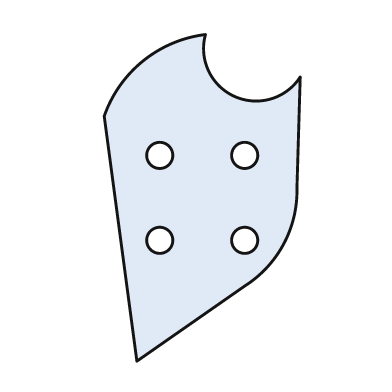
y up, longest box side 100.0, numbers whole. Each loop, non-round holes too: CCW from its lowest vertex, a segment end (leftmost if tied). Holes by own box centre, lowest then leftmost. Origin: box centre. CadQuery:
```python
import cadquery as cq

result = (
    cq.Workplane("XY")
    .moveTo(-20.0, -50.0)
    .lineTo(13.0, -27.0)
    .threePointArc((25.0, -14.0), (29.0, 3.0))
    .lineTo(30.0, 37.0)
    .threePointArc((10.0, 31.0), (1.0, 50.0))
    .threePointArc((-18.0, 42.0), (-30.0, 25.0))
    .close()
    .moveTo(-13.0, -13.0)
    .circle(4.0)
    .moveTo(13.0, -13.0)
    .circle(4.0)
    .moveTo(-13.0, 13.0)
    .circle(4.0)
    .moveTo(13.0, 13.0)
    .circle(4.0)
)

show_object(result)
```